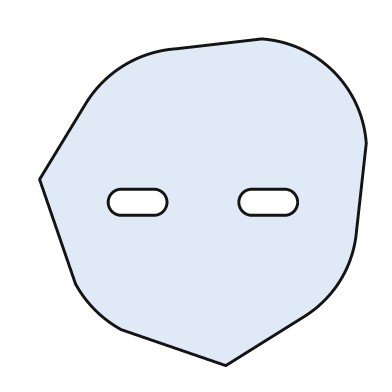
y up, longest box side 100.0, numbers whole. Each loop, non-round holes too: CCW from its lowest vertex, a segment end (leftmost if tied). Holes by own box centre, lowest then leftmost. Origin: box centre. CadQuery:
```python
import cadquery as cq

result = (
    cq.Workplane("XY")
    .moveTo(7.0, -50.0)
    .lineTo(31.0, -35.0)
    .threePointArc((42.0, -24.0), (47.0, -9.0))
    .lineTo(50.0, 18.0)
    .threePointArc((40.0, 40.0), (18.0, 50.0))
    .lineTo(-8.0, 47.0)
    .threePointArc((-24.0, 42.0), (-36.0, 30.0))
    .lineTo(-50.0, 7.0)
    .lineTo(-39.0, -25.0)
    .threePointArc((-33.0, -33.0), (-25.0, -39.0))
    .close()
    .moveTo(-25.0, -4.0)
    .lineTo(-15.0, -4.0)
    .threePointArc((-11.0, 0.0), (-15.0, 4.0))
    .lineTo(-25.0, 4.0)
    .threePointArc((-29.0, 0.0), (-25.0, -4.0))
    .close()
    .moveTo(15.0, -4.0)
    .lineTo(25.0, -4.0)
    .threePointArc((29.0, 0.0), (25.0, 4.0))
    .lineTo(15.0, 4.0)
    .threePointArc((11.0, 0.0), (15.0, -4.0))
    .close()
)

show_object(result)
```